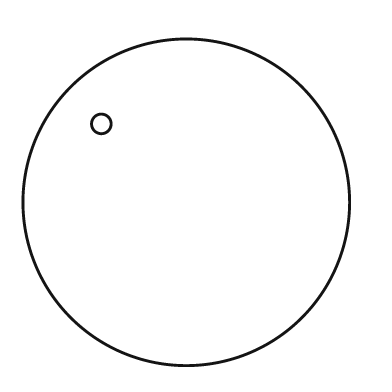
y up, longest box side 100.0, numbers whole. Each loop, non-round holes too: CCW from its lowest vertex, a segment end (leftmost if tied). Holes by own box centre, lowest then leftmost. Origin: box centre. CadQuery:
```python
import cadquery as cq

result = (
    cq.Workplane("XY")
    .moveTo(0.0, 0.0)
    .circle(50.0)
    .moveTo(-26.0, 24.0)
    .circle(3.0)
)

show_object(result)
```